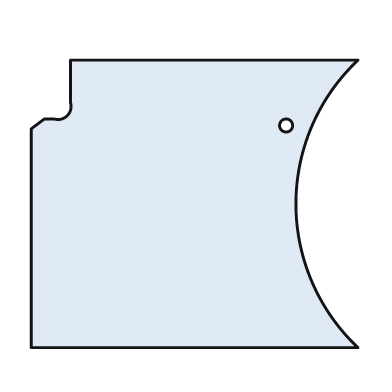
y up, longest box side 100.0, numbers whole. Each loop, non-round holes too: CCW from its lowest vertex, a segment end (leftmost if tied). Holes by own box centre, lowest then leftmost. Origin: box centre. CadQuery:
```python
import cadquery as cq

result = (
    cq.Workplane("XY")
    .moveTo(-50.0, -44.0)
    .lineTo(50.0, -44.0)
    .threePointArc((31.0, 0.0), (50.0, 44.0))
    .lineTo(-38.0, 44.0)
    .lineTo(-38.0, 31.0)
    .threePointArc((-39.0, 27.0), (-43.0, 26.0))
    .lineTo(-46.0, 26.0)
    .lineTo(-50.0, 23.0)
    .close()
    .moveTo(28.0, 24.0)
    .circle(2.0)
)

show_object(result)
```